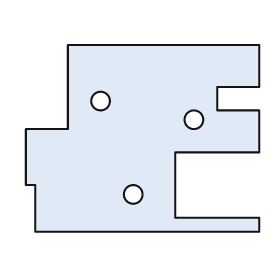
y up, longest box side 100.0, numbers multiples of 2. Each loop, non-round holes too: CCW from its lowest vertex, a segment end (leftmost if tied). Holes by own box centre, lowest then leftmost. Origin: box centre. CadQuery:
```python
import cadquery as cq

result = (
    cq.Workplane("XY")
    .moveTo(-46.0, -40.0)
    .lineTo(50.0, -40.0)
    .lineTo(50.0, -34.0)
    .lineTo(14.0, -34.0)
    .lineTo(14.0, -6.0)
    .lineTo(50.0, -6.0)
    .lineTo(50.0, 12.0)
    .lineTo(32.0, 12.0)
    .lineTo(32.0, 22.0)
    .lineTo(50.0, 22.0)
    .lineTo(50.0, 40.0)
    .lineTo(-32.0, 40.0)
    .lineTo(-32.0, 4.0)
    .lineTo(-50.0, 4.0)
    .lineTo(-50.0, -20.0)
    .lineTo(-46.0, -20.0)
    .close()
    .moveTo(-4.0, -24.0)
    .circle(4.0)
    .moveTo(22.0, 8.0)
    .circle(4.0)
    .moveTo(-18.0, 16.0)
    .circle(4.0)
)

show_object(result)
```